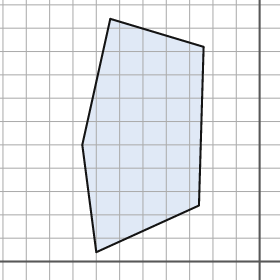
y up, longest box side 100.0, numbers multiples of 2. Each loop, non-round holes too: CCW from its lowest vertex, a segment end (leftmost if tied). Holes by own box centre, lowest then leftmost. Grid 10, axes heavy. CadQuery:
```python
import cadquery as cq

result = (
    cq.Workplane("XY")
    .moveTo(-70.0, 4.0)
    .lineTo(-26.0, 24.0)
    .lineTo(-24.0, 92.0)
    .lineTo(-64.0, 104.0)
    .lineTo(-76.0, 50.0)
    .close()
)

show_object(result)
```